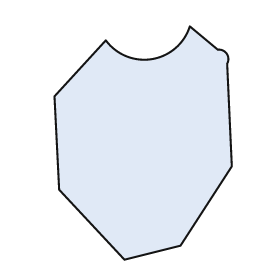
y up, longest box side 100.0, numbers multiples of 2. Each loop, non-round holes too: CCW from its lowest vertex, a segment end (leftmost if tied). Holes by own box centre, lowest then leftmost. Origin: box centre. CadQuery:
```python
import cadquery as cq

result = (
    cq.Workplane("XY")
    .moveTo(-8.0, -50.0)
    .lineTo(16.0, -44.0)
    .lineTo(38.0, -10.0)
    .lineTo(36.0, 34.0)
    .threePointArc((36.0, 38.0), (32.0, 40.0))
    .lineTo(20.0, 50.0)
    .threePointArc((4.0, 36.0), (-16.0, 44.0))
    .lineTo(-38.0, 20.0)
    .lineTo(-36.0, -20.0)
    .close()
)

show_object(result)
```